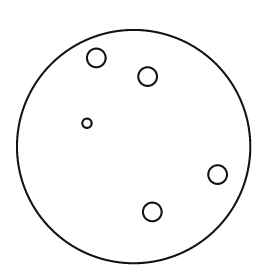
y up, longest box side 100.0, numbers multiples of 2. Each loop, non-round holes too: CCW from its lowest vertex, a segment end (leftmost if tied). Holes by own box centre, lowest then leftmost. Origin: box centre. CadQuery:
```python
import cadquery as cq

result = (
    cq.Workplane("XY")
    .moveTo(0.0, 0.0)
    .circle(50.0)
    .moveTo(8.0, -28.0)
    .circle(4.0)
    .moveTo(36.0, -12.0)
    .circle(4.0)
    .moveTo(-20.0, 10.0)
    .circle(2.0)
    .moveTo(6.0, 30.0)
    .circle(4.0)
    .moveTo(-16.0, 38.0)
    .circle(4.0)
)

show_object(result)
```